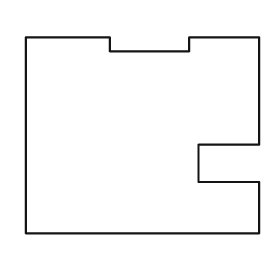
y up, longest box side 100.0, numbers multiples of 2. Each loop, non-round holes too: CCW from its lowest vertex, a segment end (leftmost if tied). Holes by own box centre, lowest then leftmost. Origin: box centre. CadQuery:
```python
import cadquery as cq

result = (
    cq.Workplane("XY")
    .moveTo(-50.0, -42.0)
    .lineTo(50.0, -42.0)
    .lineTo(50.0, -20.0)
    .lineTo(24.0, -20.0)
    .lineTo(24.0, -4.0)
    .lineTo(50.0, -4.0)
    .lineTo(50.0, 42.0)
    .lineTo(20.0, 42.0)
    .lineTo(20.0, 36.0)
    .lineTo(-14.0, 36.0)
    .lineTo(-14.0, 42.0)
    .lineTo(-50.0, 42.0)
    .close()
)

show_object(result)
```